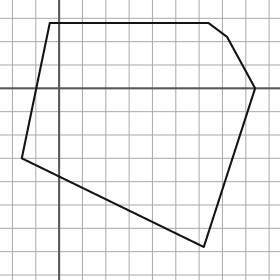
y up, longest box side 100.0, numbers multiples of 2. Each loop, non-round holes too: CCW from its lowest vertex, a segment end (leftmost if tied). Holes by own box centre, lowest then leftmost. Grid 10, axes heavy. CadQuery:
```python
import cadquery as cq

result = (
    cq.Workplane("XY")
    .moveTo(62.0, -68.0)
    .lineTo(84.0, 0.0)
    .lineTo(72.0, 22.0)
    .lineTo(64.0, 28.0)
    .lineTo(-4.0, 28.0)
    .lineTo(-16.0, -30.0)
    .close()
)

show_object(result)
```